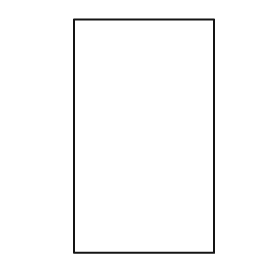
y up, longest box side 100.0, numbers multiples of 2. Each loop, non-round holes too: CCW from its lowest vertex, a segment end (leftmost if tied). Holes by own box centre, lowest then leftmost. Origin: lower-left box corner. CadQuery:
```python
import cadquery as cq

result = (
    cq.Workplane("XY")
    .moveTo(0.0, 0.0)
    .lineTo(60.0, 0.0)
    .lineTo(60.0, 100.0)
    .lineTo(0.0, 100.0)
    .close()
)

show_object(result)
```